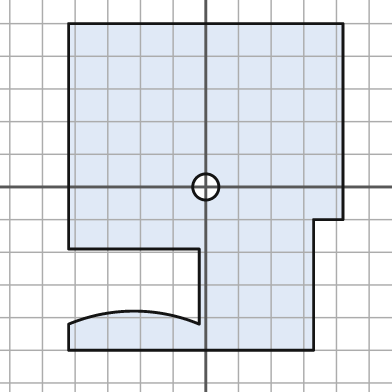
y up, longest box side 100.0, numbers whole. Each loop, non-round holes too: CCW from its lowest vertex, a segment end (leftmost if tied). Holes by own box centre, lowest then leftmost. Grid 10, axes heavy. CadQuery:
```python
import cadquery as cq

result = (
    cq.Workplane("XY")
    .moveTo(-42.0, -50.0)
    .lineTo(33.0, -50.0)
    .lineTo(33.0, -10.0)
    .lineTo(42.0, -10.0)
    .lineTo(42.0, 50.0)
    .lineTo(-42.0, 50.0)
    .lineTo(-42.0, -19.0)
    .lineTo(-2.0, -19.0)
    .lineTo(-2.0, -42.0)
    .threePointArc((-22.0, -38.0), (-42.0, -42.0))
    .close()
    .moveTo(0.0, 0.0)
    .circle(4.0)
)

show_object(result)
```